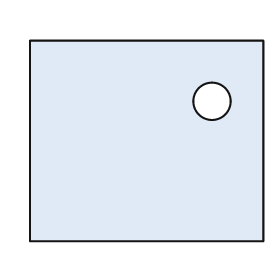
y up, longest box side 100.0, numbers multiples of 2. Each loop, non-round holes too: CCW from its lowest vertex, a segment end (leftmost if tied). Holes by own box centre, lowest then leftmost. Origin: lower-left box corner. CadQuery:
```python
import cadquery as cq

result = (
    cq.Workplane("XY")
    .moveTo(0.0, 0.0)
    .lineTo(100.0, 0.0)
    .lineTo(100.0, 86.0)
    .lineTo(0.0, 86.0)
    .close()
    .moveTo(78.0, 60.0)
    .circle(8.0)
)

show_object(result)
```